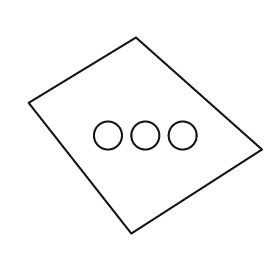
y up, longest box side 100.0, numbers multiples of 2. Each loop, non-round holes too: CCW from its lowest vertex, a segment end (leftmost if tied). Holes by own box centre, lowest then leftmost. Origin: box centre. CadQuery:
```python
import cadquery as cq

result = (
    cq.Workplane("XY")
    .moveTo(-6.0, -42.0)
    .lineTo(50.0, -6.0)
    .lineTo(-4.0, 42.0)
    .lineTo(-50.0, 14.0)
    .close()
    .moveTo(-16.0, 0.0)
    .circle(6.0)
    .moveTo(0.0, 0.0)
    .circle(6.0)
    .moveTo(16.0, 0.0)
    .circle(6.0)
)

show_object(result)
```